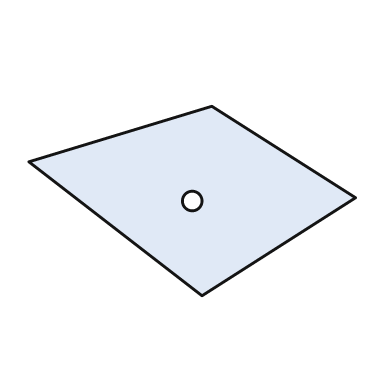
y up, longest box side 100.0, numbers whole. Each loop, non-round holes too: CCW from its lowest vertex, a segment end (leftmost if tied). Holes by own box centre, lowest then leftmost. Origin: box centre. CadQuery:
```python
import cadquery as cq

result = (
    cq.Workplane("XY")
    .moveTo(3.0, -29.0)
    .lineTo(50.0, 1.0)
    .lineTo(6.0, 29.0)
    .lineTo(-50.0, 12.0)
    .close()
    .moveTo(0.0, 0.0)
    .circle(3.0)
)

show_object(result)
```